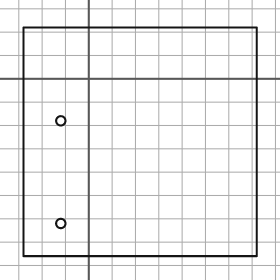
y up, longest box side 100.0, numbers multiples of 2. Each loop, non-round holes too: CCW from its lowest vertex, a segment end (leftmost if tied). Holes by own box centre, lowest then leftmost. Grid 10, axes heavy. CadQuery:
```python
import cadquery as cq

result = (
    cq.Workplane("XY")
    .moveTo(-28.0, -76.0)
    .lineTo(72.0, -76.0)
    .lineTo(72.0, 22.0)
    .lineTo(-28.0, 22.0)
    .close()
    .moveTo(-12.0, -62.0)
    .circle(2.0)
    .moveTo(-12.0, -18.0)
    .circle(2.0)
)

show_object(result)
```